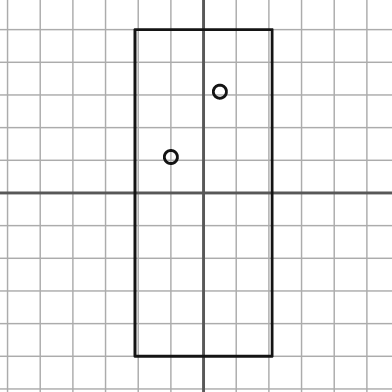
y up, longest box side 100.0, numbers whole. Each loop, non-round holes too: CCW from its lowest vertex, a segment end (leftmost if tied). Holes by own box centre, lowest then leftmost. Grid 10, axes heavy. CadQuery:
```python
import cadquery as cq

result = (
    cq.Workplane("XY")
    .moveTo(-21.0, -50.0)
    .lineTo(21.0, -50.0)
    .lineTo(21.0, 50.0)
    .lineTo(-21.0, 50.0)
    .close()
    .moveTo(-10.0, 11.0)
    .circle(2.0)
    .moveTo(5.0, 31.0)
    .circle(2.0)
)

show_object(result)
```